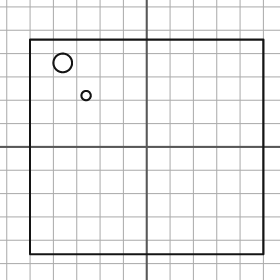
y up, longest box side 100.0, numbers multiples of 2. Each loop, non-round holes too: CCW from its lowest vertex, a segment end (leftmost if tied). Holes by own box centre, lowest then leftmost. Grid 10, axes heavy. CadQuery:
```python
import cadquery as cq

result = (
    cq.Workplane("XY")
    .moveTo(-50.0, -46.0)
    .lineTo(50.0, -46.0)
    .lineTo(50.0, 46.0)
    .lineTo(-50.0, 46.0)
    .close()
    .moveTo(-26.0, 22.0)
    .circle(2.0)
    .moveTo(-36.0, 36.0)
    .circle(4.0)
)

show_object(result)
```